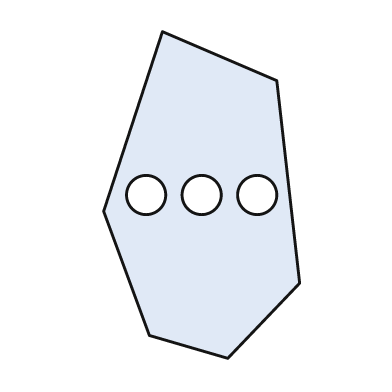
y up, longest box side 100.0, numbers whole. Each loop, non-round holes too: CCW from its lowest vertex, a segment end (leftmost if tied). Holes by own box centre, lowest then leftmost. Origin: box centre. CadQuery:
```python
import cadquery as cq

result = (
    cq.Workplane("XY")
    .moveTo(8.0, -50.0)
    .lineTo(30.0, -27.0)
    .lineTo(23.0, 35.0)
    .lineTo(-12.0, 50.0)
    .lineTo(-30.0, -5.0)
    .lineTo(-16.0, -43.0)
    .close()
    .moveTo(-17.0, 0.0)
    .circle(6.0)
    .moveTo(0.0, 0.0)
    .circle(6.0)
    .moveTo(17.0, 0.0)
    .circle(6.0)
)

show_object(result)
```